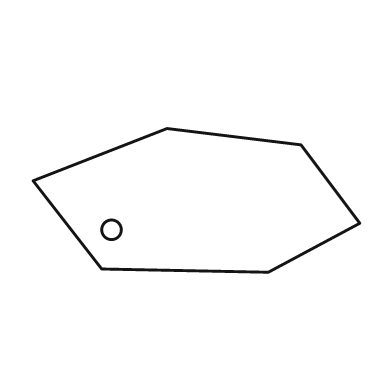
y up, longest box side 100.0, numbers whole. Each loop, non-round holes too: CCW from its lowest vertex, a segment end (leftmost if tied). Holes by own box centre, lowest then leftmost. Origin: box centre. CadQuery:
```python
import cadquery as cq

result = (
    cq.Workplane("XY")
    .moveTo(22.0, -22.0)
    .lineTo(50.0, -7.0)
    .lineTo(32.0, 17.0)
    .lineTo(-9.0, 22.0)
    .lineTo(-50.0, 6.0)
    .lineTo(-29.0, -21.0)
    .close()
    .moveTo(-26.0, -9.0)
    .circle(3.0)
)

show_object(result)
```